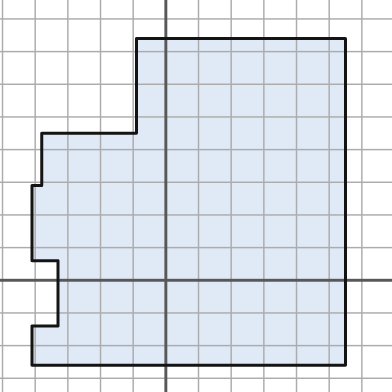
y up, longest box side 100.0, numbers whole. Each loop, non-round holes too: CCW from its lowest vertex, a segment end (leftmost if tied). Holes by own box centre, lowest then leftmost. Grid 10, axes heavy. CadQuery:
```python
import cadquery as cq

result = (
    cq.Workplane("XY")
    .moveTo(-41.0, -26.0)
    .lineTo(55.0, -26.0)
    .lineTo(55.0, 74.0)
    .lineTo(-9.0, 74.0)
    .lineTo(-9.0, 45.0)
    .lineTo(-38.0, 45.0)
    .lineTo(-38.0, 29.0)
    .lineTo(-41.0, 29.0)
    .lineTo(-41.0, 6.0)
    .lineTo(-33.0, 6.0)
    .lineTo(-33.0, -14.0)
    .lineTo(-41.0, -14.0)
    .close()
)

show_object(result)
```